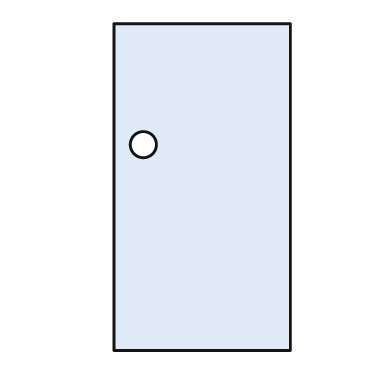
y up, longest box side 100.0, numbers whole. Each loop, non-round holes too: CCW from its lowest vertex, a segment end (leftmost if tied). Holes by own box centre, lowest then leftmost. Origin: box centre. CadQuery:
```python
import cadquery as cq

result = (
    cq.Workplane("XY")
    .moveTo(-27.0, -50.0)
    .lineTo(27.0, -50.0)
    .lineTo(27.0, 50.0)
    .lineTo(-27.0, 50.0)
    .close()
    .moveTo(-18.0, 13.0)
    .circle(4.0)
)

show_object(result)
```